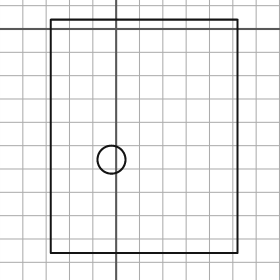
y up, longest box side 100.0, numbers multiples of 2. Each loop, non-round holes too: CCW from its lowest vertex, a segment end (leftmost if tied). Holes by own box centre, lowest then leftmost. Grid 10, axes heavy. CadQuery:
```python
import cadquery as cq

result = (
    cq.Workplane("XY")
    .moveTo(-28.0, -96.0)
    .lineTo(52.0, -96.0)
    .lineTo(52.0, 4.0)
    .lineTo(-28.0, 4.0)
    .close()
    .moveTo(-2.0, -56.0)
    .circle(6.0)
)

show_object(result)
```